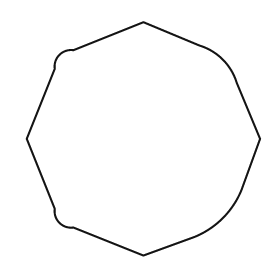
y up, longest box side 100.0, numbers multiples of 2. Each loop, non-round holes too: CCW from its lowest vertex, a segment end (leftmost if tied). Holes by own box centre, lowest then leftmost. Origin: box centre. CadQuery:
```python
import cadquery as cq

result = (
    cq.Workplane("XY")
    .moveTo(0.0, -50.0)
    .lineTo(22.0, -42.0)
    .threePointArc((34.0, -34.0), (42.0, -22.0))
    .lineTo(50.0, 0.0)
    .lineTo(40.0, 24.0)
    .threePointArc((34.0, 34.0), (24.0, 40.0))
    .lineTo(0.0, 50.0)
    .lineTo(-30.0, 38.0)
    .threePointArc((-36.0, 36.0), (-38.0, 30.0))
    .lineTo(-50.0, 0.0)
    .lineTo(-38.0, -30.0)
    .threePointArc((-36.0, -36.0), (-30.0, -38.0))
    .close()
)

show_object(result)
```